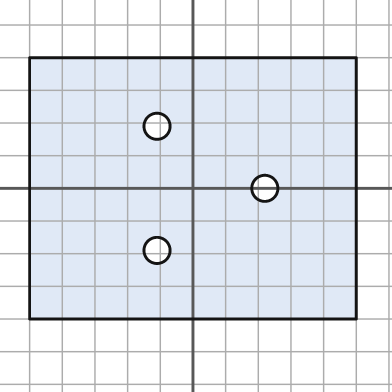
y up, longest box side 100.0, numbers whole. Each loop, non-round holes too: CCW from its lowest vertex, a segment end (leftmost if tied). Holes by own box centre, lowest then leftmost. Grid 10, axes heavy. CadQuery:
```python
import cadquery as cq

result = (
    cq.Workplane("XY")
    .moveTo(-50.0, -40.0)
    .lineTo(50.0, -40.0)
    .lineTo(50.0, 40.0)
    .lineTo(-50.0, 40.0)
    .close()
    .moveTo(-11.0, -19.0)
    .circle(4.0)
    .moveTo(22.0, 0.0)
    .circle(4.0)
    .moveTo(-11.0, 19.0)
    .circle(4.0)
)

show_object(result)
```